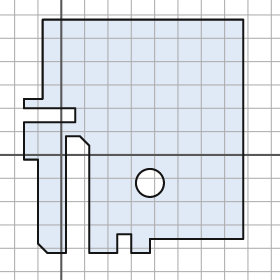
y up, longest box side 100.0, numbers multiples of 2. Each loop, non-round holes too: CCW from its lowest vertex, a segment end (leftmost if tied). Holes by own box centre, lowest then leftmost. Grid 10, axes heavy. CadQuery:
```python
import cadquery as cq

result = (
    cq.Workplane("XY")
    .moveTo(-6.0, -42.0)
    .lineTo(2.0, -42.0)
    .lineTo(2.0, 8.0)
    .lineTo(8.0, 8.0)
    .lineTo(12.0, 4.0)
    .lineTo(12.0, -42.0)
    .lineTo(24.0, -42.0)
    .lineTo(24.0, -34.0)
    .lineTo(30.0, -34.0)
    .lineTo(30.0, -42.0)
    .lineTo(38.0, -42.0)
    .lineTo(38.0, -36.0)
    .lineTo(78.0, -36.0)
    .lineTo(78.0, 58.0)
    .lineTo(-8.0, 58.0)
    .lineTo(-8.0, 24.0)
    .lineTo(-16.0, 24.0)
    .lineTo(-16.0, 20.0)
    .lineTo(6.0, 20.0)
    .lineTo(6.0, 14.0)
    .lineTo(-16.0, 14.0)
    .lineTo(-16.0, -2.0)
    .lineTo(-10.0, -2.0)
    .lineTo(-10.0, -38.0)
    .close()
    .moveTo(38.0, -12.0)
    .circle(6.0)
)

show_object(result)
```